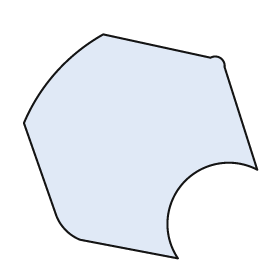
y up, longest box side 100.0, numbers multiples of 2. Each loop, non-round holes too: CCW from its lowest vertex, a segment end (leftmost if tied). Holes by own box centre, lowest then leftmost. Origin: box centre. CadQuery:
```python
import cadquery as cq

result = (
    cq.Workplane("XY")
    .moveTo(16.0, -48.0)
    .threePointArc((18.0, -16.0), (50.0, -10.0))
    .lineTo(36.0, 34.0)
    .threePointArc((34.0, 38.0), (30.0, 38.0))
    .lineTo(-16.0, 48.0)
    .threePointArc((-36.0, 32.0), (-50.0, 10.0))
    .lineTo(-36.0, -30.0)
    .threePointArc((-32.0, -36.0), (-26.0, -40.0))
    .close()
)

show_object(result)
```